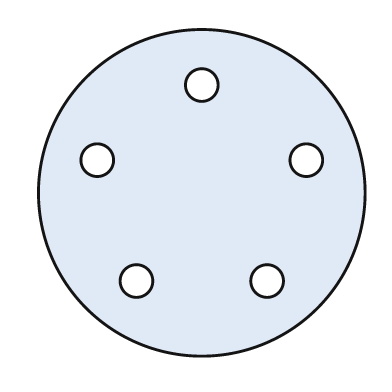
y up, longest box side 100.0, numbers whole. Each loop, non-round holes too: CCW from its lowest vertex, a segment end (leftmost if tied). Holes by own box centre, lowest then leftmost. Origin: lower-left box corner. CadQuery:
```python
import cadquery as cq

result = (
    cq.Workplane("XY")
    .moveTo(50.0, 50.0)
    .circle(50.0)
    .moveTo(30.0, 23.0)
    .circle(5.0)
    .moveTo(70.0, 23.0)
    .circle(5.0)
    .moveTo(18.0, 60.0)
    .circle(5.0)
    .moveTo(82.0, 60.0)
    .circle(5.0)
    .moveTo(50.0, 83.0)
    .circle(5.0)
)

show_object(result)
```